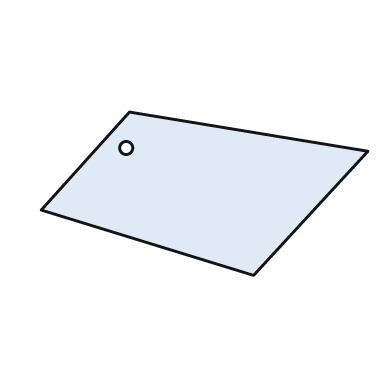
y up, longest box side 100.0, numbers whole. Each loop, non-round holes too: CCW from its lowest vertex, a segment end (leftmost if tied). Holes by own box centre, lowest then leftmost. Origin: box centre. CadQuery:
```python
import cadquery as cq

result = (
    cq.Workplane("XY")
    .moveTo(15.0, -25.0)
    .lineTo(50.0, 13.0)
    .lineTo(-23.0, 25.0)
    .lineTo(-50.0, -5.0)
    .close()
    .moveTo(-24.0, 14.0)
    .circle(2.0)
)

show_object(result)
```